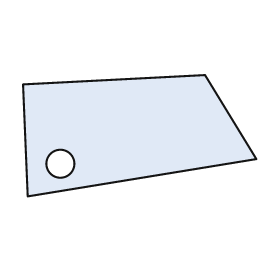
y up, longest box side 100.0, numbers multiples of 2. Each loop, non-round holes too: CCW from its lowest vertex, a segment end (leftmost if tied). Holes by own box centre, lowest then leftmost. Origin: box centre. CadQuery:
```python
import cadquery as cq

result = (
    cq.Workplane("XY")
    .moveTo(-48.0, -26.0)
    .lineTo(50.0, -10.0)
    .lineTo(28.0, 26.0)
    .lineTo(-50.0, 22.0)
    .close()
    .moveTo(-34.0, -12.0)
    .circle(6.0)
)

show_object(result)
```